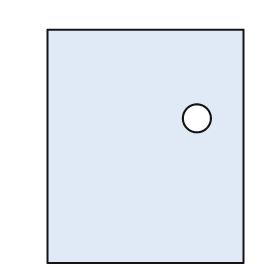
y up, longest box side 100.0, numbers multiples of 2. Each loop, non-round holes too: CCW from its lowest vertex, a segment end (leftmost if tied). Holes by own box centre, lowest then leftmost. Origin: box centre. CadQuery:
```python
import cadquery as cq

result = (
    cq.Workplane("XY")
    .moveTo(-42.0, -50.0)
    .lineTo(42.0, -50.0)
    .lineTo(42.0, 50.0)
    .lineTo(-42.0, 50.0)
    .close()
    .moveTo(22.0, 12.0)
    .circle(6.0)
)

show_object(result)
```